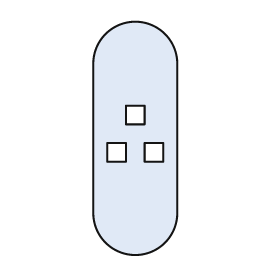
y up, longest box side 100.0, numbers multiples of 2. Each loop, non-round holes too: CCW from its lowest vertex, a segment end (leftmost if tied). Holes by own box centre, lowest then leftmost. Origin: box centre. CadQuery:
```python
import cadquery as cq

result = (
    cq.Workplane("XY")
    .moveTo(-18.0, -32.0)
    .threePointArc((0.0, -50.0), (18.0, -32.0))
    .lineTo(18.0, 32.0)
    .threePointArc((0.0, 50.0), (-18.0, 32.0))
    .close()
    .moveTo(-12.0, -10.0)
    .lineTo(-4.0, -10.0)
    .lineTo(-4.0, -2.0)
    .lineTo(-12.0, -2.0)
    .close()
    .moveTo(4.0, -10.0)
    .lineTo(12.0, -10.0)
    .lineTo(12.0, -2.0)
    .lineTo(4.0, -2.0)
    .close()
    .moveTo(-4.0, 6.0)
    .lineTo(4.0, 6.0)
    .lineTo(4.0, 14.0)
    .lineTo(-4.0, 14.0)
    .close()
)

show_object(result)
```